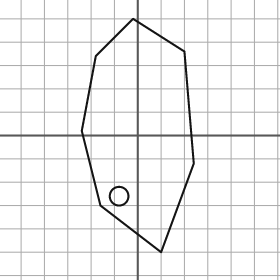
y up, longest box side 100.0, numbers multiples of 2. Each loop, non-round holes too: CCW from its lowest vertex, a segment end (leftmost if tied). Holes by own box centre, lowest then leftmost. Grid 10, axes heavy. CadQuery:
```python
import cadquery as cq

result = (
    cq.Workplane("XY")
    .moveTo(10.0, -50.0)
    .lineTo(24.0, -12.0)
    .lineTo(20.0, 36.0)
    .lineTo(-2.0, 50.0)
    .lineTo(-18.0, 34.0)
    .lineTo(-24.0, 2.0)
    .lineTo(-16.0, -30.0)
    .close()
    .moveTo(-8.0, -26.0)
    .circle(4.0)
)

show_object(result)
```